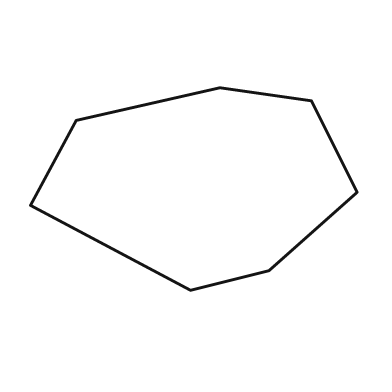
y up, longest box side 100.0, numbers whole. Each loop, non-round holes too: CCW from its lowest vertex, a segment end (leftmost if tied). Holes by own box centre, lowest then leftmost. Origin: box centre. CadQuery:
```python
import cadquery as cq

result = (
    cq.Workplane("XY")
    .moveTo(-1.0, -31.0)
    .lineTo(23.0, -25.0)
    .lineTo(50.0, -1.0)
    .lineTo(36.0, 27.0)
    .lineTo(8.0, 31.0)
    .lineTo(-36.0, 21.0)
    .lineTo(-50.0, -5.0)
    .close()
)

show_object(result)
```